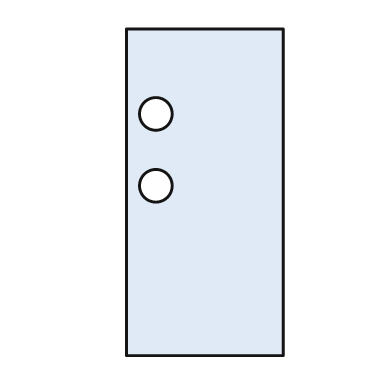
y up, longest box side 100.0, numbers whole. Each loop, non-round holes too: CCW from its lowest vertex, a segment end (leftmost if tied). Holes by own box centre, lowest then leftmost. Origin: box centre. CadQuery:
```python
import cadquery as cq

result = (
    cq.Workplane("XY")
    .moveTo(-24.0, -50.0)
    .lineTo(24.0, -50.0)
    .lineTo(24.0, 50.0)
    .lineTo(-24.0, 50.0)
    .close()
    .moveTo(-15.0, 2.0)
    .circle(5.0)
    .moveTo(-15.0, 24.0)
    .circle(5.0)
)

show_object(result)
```